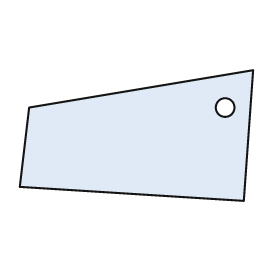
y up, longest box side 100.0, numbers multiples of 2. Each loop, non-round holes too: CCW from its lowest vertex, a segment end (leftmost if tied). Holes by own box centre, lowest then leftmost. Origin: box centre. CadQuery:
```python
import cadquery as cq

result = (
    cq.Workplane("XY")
    .moveTo(46.0, -28.0)
    .lineTo(50.0, 28.0)
    .lineTo(-46.0, 12.0)
    .lineTo(-50.0, -22.0)
    .close()
    .moveTo(38.0, 12.0)
    .circle(4.0)
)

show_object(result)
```